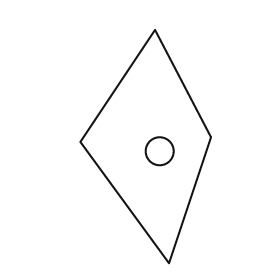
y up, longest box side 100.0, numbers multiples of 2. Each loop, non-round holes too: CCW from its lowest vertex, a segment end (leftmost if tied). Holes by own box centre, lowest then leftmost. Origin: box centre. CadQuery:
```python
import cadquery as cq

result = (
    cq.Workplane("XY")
    .moveTo(10.0, -50.0)
    .lineTo(28.0, 4.0)
    .lineTo(4.0, 50.0)
    .lineTo(-28.0, 2.0)
    .close()
    .moveTo(6.0, -2.0)
    .circle(6.0)
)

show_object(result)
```